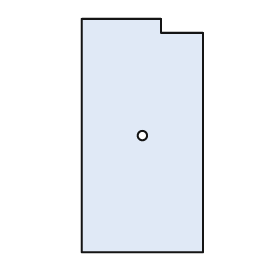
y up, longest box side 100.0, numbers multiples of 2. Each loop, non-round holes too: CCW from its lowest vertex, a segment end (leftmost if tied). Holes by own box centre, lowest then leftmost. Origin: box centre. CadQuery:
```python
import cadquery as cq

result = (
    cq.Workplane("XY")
    .moveTo(-26.0, -50.0)
    .lineTo(26.0, -50.0)
    .lineTo(26.0, 44.0)
    .lineTo(8.0, 44.0)
    .lineTo(8.0, 50.0)
    .lineTo(-26.0, 50.0)
    .close()
    .moveTo(0.0, 0.0)
    .circle(2.0)
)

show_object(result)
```